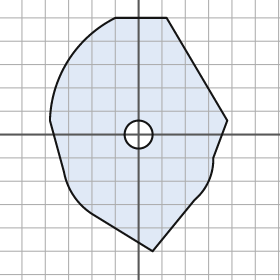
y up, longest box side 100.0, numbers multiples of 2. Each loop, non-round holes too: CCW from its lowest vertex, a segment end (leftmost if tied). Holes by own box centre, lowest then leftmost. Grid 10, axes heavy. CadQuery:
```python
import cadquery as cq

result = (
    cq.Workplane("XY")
    .moveTo(6.0, -50.0)
    .lineTo(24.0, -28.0)
    .threePointArc((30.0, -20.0), (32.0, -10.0))
    .lineTo(38.0, 6.0)
    .lineTo(12.0, 50.0)
    .lineTo(-10.0, 50.0)
    .threePointArc((-30.0, 32.0), (-38.0, 6.0))
    .lineTo(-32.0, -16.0)
    .threePointArc((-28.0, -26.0), (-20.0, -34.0))
    .close()
    .moveTo(0.0, 0.0)
    .circle(6.0)
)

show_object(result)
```